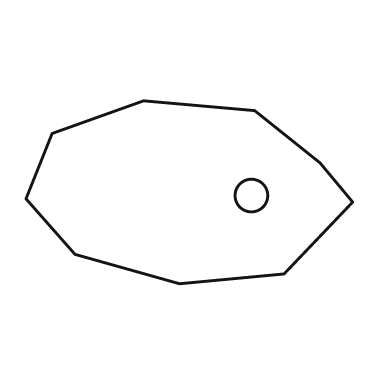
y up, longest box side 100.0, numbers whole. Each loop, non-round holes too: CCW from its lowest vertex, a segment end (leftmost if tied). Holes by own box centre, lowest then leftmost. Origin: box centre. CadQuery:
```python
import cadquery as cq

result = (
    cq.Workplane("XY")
    .moveTo(-3.0, -28.0)
    .lineTo(29.0, -25.0)
    .lineTo(50.0, -3.0)
    .lineTo(40.0, 9.0)
    .lineTo(20.0, 25.0)
    .lineTo(-14.0, 28.0)
    .lineTo(-42.0, 18.0)
    .lineTo(-50.0, -2.0)
    .lineTo(-35.0, -19.0)
    .close()
    .moveTo(19.0, -1.0)
    .circle(5.0)
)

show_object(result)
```